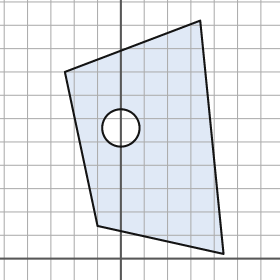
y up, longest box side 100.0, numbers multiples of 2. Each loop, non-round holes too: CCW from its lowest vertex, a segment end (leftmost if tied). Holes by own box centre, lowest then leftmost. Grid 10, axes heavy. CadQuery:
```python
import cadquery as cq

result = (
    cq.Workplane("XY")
    .moveTo(44.0, 2.0)
    .lineTo(34.0, 102.0)
    .lineTo(-24.0, 80.0)
    .lineTo(-10.0, 14.0)
    .close()
    .moveTo(0.0, 56.0)
    .circle(8.0)
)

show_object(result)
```